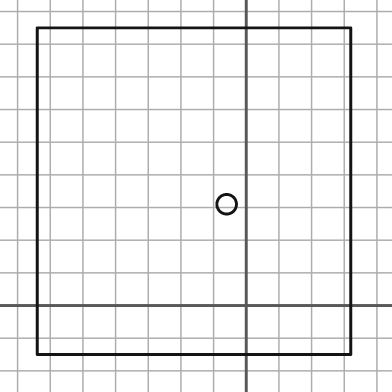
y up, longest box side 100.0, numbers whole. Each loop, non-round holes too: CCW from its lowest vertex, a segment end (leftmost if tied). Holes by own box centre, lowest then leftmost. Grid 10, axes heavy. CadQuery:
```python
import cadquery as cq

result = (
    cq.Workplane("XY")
    .moveTo(-64.0, -15.0)
    .lineTo(32.0, -15.0)
    .lineTo(32.0, 85.0)
    .lineTo(-64.0, 85.0)
    .close()
    .moveTo(-6.0, 31.0)
    .circle(3.0)
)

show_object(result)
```